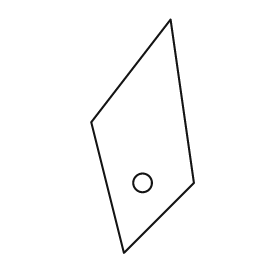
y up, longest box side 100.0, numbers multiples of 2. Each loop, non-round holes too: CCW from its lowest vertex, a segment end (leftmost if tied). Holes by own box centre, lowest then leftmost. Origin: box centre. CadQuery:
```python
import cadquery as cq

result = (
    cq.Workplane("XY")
    .moveTo(-8.0, -50.0)
    .lineTo(22.0, -20.0)
    .lineTo(12.0, 50.0)
    .lineTo(-22.0, 6.0)
    .close()
    .moveTo(0.0, -20.0)
    .circle(4.0)
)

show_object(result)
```